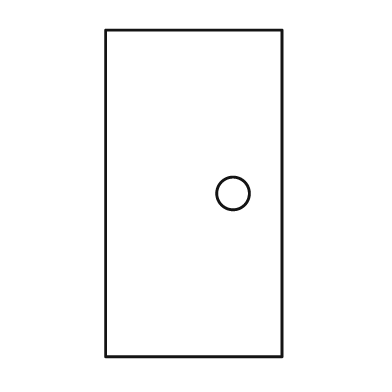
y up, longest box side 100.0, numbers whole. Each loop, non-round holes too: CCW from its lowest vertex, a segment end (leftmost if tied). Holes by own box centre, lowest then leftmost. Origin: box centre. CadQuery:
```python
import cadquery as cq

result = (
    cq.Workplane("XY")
    .moveTo(-27.0, -50.0)
    .lineTo(27.0, -50.0)
    .lineTo(27.0, 50.0)
    .lineTo(-27.0, 50.0)
    .close()
    .moveTo(12.0, 0.0)
    .circle(5.0)
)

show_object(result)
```